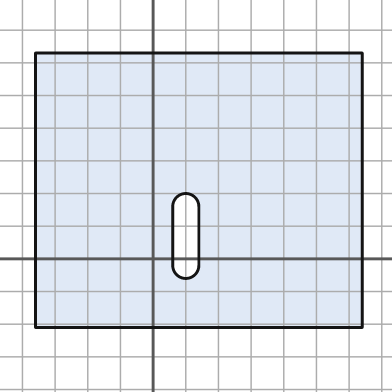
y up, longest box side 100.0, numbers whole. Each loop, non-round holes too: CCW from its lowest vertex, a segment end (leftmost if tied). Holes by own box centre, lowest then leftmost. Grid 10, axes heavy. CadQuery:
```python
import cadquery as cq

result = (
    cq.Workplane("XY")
    .moveTo(-36.0, -21.0)
    .lineTo(64.0, -21.0)
    .lineTo(64.0, 63.0)
    .lineTo(-36.0, 63.0)
    .close()
    .moveTo(6.0, -2.0)
    .threePointArc((10.0, -6.0), (14.0, -2.0))
    .lineTo(14.0, 16.0)
    .threePointArc((10.0, 20.0), (6.0, 16.0))
    .close()
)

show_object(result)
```